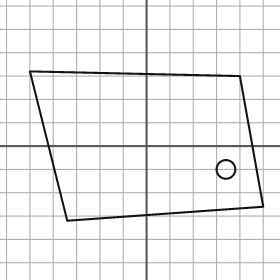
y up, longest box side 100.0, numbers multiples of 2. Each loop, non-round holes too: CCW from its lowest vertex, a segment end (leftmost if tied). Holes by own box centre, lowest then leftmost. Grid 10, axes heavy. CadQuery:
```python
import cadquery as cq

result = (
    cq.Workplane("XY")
    .moveTo(-34.0, -32.0)
    .lineTo(50.0, -26.0)
    .lineTo(40.0, 30.0)
    .lineTo(-50.0, 32.0)
    .close()
    .moveTo(34.0, -10.0)
    .circle(4.0)
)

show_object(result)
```